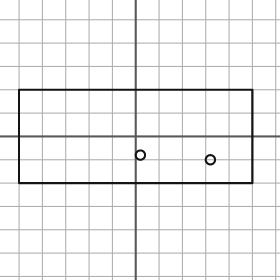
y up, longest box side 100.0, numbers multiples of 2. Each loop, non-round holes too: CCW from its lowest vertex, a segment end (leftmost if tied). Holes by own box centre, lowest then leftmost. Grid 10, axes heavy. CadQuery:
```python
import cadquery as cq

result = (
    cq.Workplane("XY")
    .moveTo(-50.0, -20.0)
    .lineTo(50.0, -20.0)
    .lineTo(50.0, 20.0)
    .lineTo(-50.0, 20.0)
    .close()
    .moveTo(32.0, -10.0)
    .circle(2.0)
    .moveTo(2.0, -8.0)
    .circle(2.0)
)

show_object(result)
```